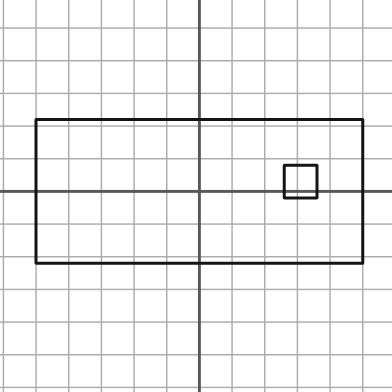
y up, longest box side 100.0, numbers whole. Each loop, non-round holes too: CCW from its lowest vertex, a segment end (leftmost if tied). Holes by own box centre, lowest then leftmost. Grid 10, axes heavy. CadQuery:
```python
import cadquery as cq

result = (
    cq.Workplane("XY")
    .moveTo(-50.0, -22.0)
    .lineTo(50.0, -22.0)
    .lineTo(50.0, 22.0)
    .lineTo(-50.0, 22.0)
    .close()
    .moveTo(26.0, -2.0)
    .lineTo(36.0, -2.0)
    .lineTo(36.0, 8.0)
    .lineTo(26.0, 8.0)
    .close()
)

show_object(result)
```